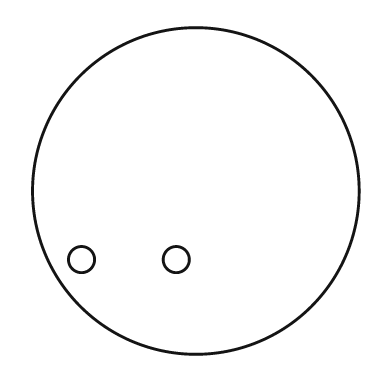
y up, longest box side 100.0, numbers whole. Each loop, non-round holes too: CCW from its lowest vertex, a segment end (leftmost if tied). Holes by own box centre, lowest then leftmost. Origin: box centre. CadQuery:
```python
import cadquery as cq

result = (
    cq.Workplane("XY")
    .moveTo(0.0, 0.0)
    .circle(50.0)
    .moveTo(-35.0, -21.0)
    .circle(4.0)
    .moveTo(-6.0, -21.0)
    .circle(4.0)
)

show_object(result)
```